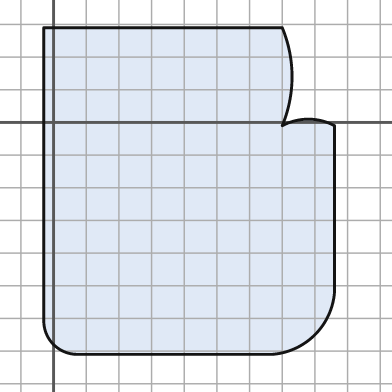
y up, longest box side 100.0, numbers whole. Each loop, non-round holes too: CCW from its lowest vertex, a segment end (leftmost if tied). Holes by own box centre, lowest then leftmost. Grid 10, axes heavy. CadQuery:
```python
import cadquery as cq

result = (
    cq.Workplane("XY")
    .moveTo(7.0, -71.0)
    .lineTo(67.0, -71.0)
    .threePointArc((80.0, -65.0), (86.0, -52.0))
    .lineTo(86.0, -1.0)
    .threePointArc((78.0, 1.0), (70.0, -1.0))
    .threePointArc((73.0, 14.0), (70.0, 29.0))
    .lineTo(-3.0, 29.0)
    .lineTo(-3.0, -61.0)
    .threePointArc((0.0, -68.0), (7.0, -71.0))
    .close()
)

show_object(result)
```